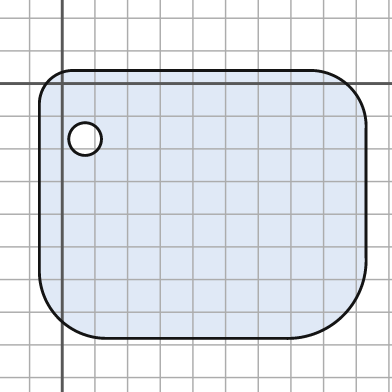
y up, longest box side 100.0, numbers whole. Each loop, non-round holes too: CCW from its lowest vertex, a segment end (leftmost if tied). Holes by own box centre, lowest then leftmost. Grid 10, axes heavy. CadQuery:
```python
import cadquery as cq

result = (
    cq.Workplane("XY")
    .moveTo(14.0, -78.0)
    .lineTo(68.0, -78.0)
    .threePointArc((86.0, -71.0), (93.0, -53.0))
    .lineTo(93.0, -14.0)
    .threePointArc((88.0, -1.0), (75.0, 4.0))
    .lineTo(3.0, 4.0)
    .threePointArc((-4.0, 1.0), (-7.0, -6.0))
    .lineTo(-7.0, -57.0)
    .threePointArc((-1.0, -72.0), (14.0, -78.0))
    .close()
    .moveTo(7.0, -17.0)
    .circle(5.0)
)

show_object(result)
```